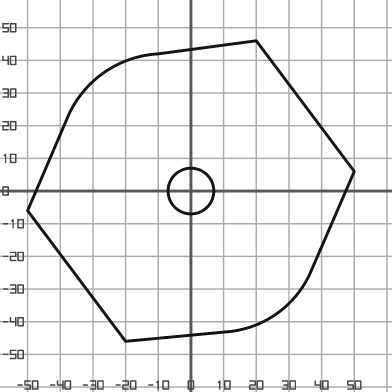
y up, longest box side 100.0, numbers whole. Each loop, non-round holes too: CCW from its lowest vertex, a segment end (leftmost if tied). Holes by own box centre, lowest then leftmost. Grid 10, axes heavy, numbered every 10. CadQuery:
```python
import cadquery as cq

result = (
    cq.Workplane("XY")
    .moveTo(-20.0, -46.0)
    .lineTo(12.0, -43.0)
    .threePointArc((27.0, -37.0), (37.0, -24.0))
    .lineTo(50.0, 6.0)
    .lineTo(20.0, 46.0)
    .lineTo(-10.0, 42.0)
    .threePointArc((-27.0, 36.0), (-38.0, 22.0))
    .lineTo(-50.0, -6.0)
    .close()
    .moveTo(0.0, 0.0)
    .circle(7.0)
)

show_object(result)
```